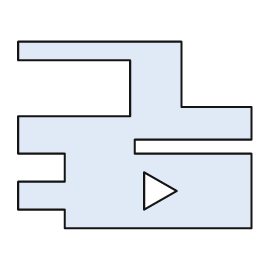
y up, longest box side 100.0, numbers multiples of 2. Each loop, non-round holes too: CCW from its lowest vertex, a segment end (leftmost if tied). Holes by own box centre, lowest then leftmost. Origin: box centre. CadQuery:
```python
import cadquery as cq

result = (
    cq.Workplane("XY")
    .moveTo(-30.0, -40.0)
    .lineTo(50.0, -40.0)
    .lineTo(50.0, -8.0)
    .lineTo(0.0, -8.0)
    .lineTo(0.0, -2.0)
    .lineTo(50.0, -2.0)
    .lineTo(50.0, 12.0)
    .lineTo(20.0, 12.0)
    .lineTo(20.0, 40.0)
    .lineTo(-50.0, 40.0)
    .lineTo(-50.0, 32.0)
    .lineTo(-2.0, 32.0)
    .lineTo(-2.0, 8.0)
    .lineTo(-50.0, 8.0)
    .lineTo(-50.0, -8.0)
    .lineTo(-30.0, -8.0)
    .lineTo(-30.0, -20.0)
    .lineTo(-50.0, -20.0)
    .lineTo(-50.0, -32.0)
    .lineTo(-30.0, -32.0)
    .close()
    .moveTo(4.0, -32.0)
    .lineTo(18.0, -24.0)
    .lineTo(4.0, -16.0)
    .close()
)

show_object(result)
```